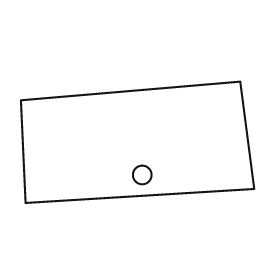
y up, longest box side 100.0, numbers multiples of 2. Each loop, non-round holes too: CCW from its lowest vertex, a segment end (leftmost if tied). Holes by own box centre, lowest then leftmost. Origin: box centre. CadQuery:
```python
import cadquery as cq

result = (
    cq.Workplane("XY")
    .moveTo(-48.0, -26.0)
    .lineTo(50.0, -20.0)
    .lineTo(44.0, 26.0)
    .lineTo(-50.0, 18.0)
    .close()
    .moveTo(2.0, -14.0)
    .circle(4.0)
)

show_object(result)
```